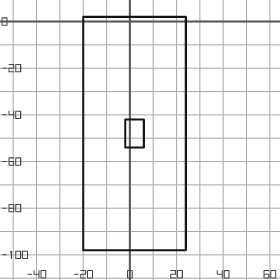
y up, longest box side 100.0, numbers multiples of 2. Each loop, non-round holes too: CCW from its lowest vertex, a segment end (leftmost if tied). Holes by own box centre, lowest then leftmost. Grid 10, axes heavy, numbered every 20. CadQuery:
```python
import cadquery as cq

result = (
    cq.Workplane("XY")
    .moveTo(-20.0, -98.0)
    .lineTo(24.0, -98.0)
    .lineTo(24.0, 2.0)
    .lineTo(-20.0, 2.0)
    .close()
    .moveTo(-2.0, -54.0)
    .lineTo(6.0, -54.0)
    .lineTo(6.0, -42.0)
    .lineTo(-2.0, -42.0)
    .close()
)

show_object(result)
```